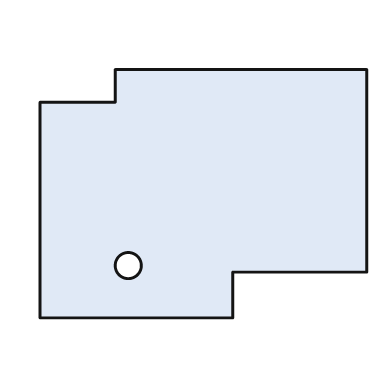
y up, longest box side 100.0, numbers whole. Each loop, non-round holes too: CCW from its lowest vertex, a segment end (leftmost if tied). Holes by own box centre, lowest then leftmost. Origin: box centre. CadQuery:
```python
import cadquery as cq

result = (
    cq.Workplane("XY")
    .moveTo(-50.0, -38.0)
    .lineTo(9.0, -38.0)
    .lineTo(9.0, -24.0)
    .lineTo(50.0, -24.0)
    .lineTo(50.0, 38.0)
    .lineTo(-27.0, 38.0)
    .lineTo(-27.0, 28.0)
    .lineTo(-50.0, 28.0)
    .close()
    .moveTo(-23.0, -22.0)
    .circle(4.0)
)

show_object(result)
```